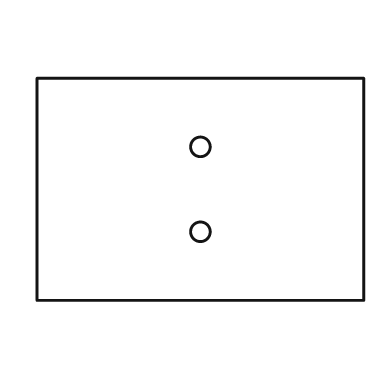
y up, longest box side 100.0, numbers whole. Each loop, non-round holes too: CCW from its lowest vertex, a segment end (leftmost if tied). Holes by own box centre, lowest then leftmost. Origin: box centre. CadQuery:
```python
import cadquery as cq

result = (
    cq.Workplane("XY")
    .moveTo(-50.0, -34.0)
    .lineTo(50.0, -34.0)
    .lineTo(50.0, 34.0)
    .lineTo(-50.0, 34.0)
    .close()
    .moveTo(0.0, -13.0)
    .circle(3.0)
    .moveTo(0.0, 13.0)
    .circle(3.0)
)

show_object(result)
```